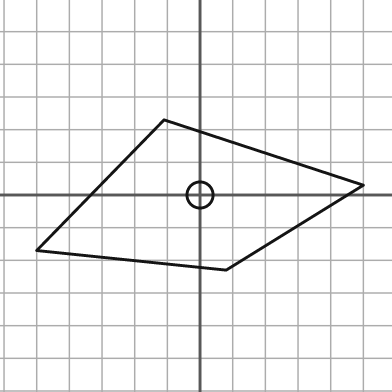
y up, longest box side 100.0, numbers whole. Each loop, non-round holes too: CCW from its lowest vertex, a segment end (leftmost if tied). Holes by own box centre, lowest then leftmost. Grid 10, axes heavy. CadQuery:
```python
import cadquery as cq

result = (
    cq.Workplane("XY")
    .moveTo(8.0, -23.0)
    .lineTo(50.0, 3.0)
    .lineTo(-11.0, 23.0)
    .lineTo(-50.0, -17.0)
    .close()
    .moveTo(0.0, 0.0)
    .circle(4.0)
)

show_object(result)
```